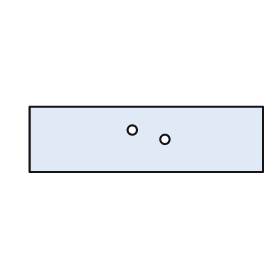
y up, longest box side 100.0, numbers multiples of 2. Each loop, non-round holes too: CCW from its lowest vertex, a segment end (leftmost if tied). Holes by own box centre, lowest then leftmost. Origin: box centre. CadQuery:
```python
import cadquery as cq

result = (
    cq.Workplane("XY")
    .moveTo(-50.0, -14.0)
    .lineTo(50.0, -14.0)
    .lineTo(50.0, 14.0)
    .lineTo(-50.0, 14.0)
    .close()
    .moveTo(8.0, 0.0)
    .circle(2.0)
    .moveTo(-6.0, 4.0)
    .circle(2.0)
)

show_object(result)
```